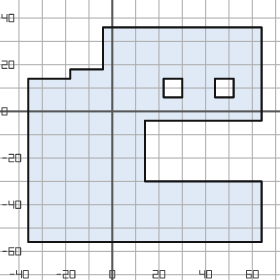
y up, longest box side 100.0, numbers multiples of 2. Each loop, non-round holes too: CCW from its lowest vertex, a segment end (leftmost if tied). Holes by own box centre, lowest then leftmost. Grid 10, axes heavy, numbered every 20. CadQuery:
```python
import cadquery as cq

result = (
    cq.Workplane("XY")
    .moveTo(-36.0, -56.0)
    .lineTo(64.0, -56.0)
    .lineTo(64.0, -30.0)
    .lineTo(14.0, -30.0)
    .lineTo(14.0, -4.0)
    .lineTo(64.0, -4.0)
    .lineTo(64.0, 36.0)
    .lineTo(-4.0, 36.0)
    .lineTo(-4.0, 18.0)
    .lineTo(-18.0, 18.0)
    .lineTo(-18.0, 14.0)
    .lineTo(-36.0, 14.0)
    .close()
    .moveTo(22.0, 6.0)
    .lineTo(30.0, 6.0)
    .lineTo(30.0, 14.0)
    .lineTo(22.0, 14.0)
    .close()
    .moveTo(44.0, 6.0)
    .lineTo(52.0, 6.0)
    .lineTo(52.0, 14.0)
    .lineTo(44.0, 14.0)
    .close()
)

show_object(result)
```